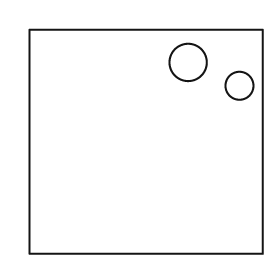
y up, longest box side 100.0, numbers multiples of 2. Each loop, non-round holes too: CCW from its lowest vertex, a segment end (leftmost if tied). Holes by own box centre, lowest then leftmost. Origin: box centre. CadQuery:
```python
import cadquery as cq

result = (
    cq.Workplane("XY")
    .moveTo(-50.0, -48.0)
    .lineTo(50.0, -48.0)
    .lineTo(50.0, 48.0)
    .lineTo(-50.0, 48.0)
    .close()
    .moveTo(40.0, 24.0)
    .circle(6.0)
    .moveTo(18.0, 34.0)
    .circle(8.0)
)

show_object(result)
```